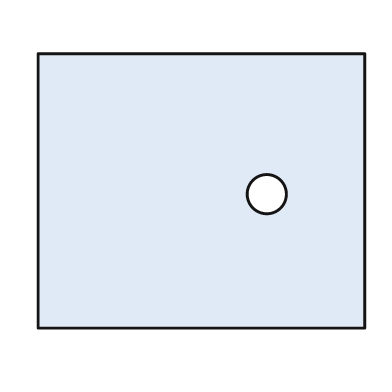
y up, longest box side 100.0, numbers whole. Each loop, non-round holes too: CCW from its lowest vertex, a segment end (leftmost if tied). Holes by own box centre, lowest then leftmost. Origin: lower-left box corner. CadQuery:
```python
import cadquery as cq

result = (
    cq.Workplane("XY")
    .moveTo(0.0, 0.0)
    .lineTo(100.0, 0.0)
    .lineTo(100.0, 84.0)
    .lineTo(0.0, 84.0)
    .close()
    .moveTo(70.0, 41.0)
    .circle(6.0)
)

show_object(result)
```